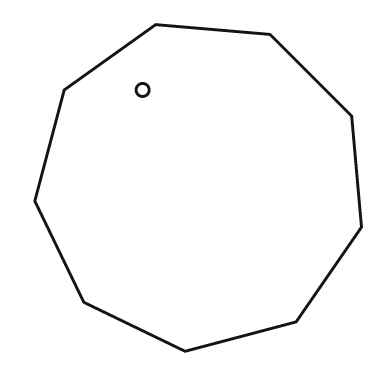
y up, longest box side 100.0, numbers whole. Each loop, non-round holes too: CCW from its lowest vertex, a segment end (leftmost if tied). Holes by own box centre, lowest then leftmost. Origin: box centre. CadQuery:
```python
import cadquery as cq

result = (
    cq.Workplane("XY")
    .moveTo(-4.0, -50.0)
    .lineTo(30.0, -41.0)
    .lineTo(50.0, -12.0)
    .lineTo(47.0, 22.0)
    .lineTo(22.0, 47.0)
    .lineTo(-13.0, 50.0)
    .lineTo(-41.0, 30.0)
    .lineTo(-50.0, -4.0)
    .lineTo(-35.0, -35.0)
    .close()
    .moveTo(-17.0, 30.0)
    .circle(2.0)
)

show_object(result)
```